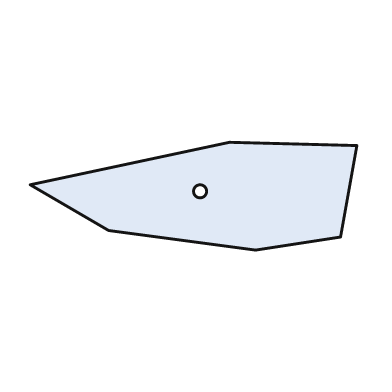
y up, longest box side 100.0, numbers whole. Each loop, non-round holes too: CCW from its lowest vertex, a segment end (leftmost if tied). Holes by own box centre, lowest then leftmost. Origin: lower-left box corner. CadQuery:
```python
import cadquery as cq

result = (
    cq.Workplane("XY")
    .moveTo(69.0, 0.0)
    .lineTo(95.0, 4.0)
    .lineTo(100.0, 32.0)
    .lineTo(61.0, 33.0)
    .lineTo(0.0, 20.0)
    .lineTo(24.0, 6.0)
    .close()
    .moveTo(52.0, 18.0)
    .circle(2.0)
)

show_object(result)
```